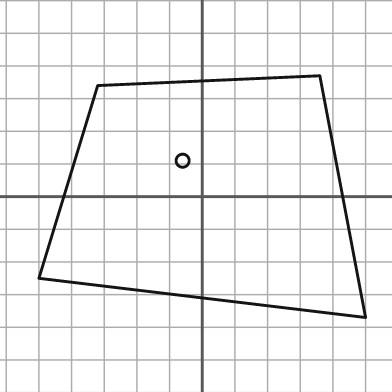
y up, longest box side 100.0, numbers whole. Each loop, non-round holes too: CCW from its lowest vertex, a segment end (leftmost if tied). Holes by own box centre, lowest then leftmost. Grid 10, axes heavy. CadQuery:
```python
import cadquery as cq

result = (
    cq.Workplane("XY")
    .moveTo(50.0, -37.0)
    .lineTo(36.0, 37.0)
    .lineTo(-32.0, 34.0)
    .lineTo(-50.0, -25.0)
    .close()
    .moveTo(-6.0, 11.0)
    .circle(2.0)
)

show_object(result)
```